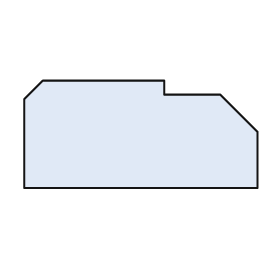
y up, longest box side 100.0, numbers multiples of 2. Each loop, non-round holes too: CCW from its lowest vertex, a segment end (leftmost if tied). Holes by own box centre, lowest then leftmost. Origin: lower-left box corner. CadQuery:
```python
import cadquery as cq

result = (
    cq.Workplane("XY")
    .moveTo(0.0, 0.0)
    .lineTo(100.0, 0.0)
    .lineTo(100.0, 24.0)
    .lineTo(84.0, 40.0)
    .lineTo(60.0, 40.0)
    .lineTo(60.0, 46.0)
    .lineTo(8.0, 46.0)
    .lineTo(0.0, 38.0)
    .close()
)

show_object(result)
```